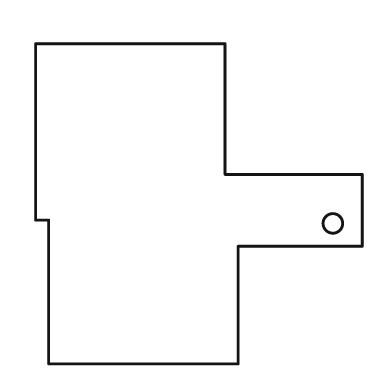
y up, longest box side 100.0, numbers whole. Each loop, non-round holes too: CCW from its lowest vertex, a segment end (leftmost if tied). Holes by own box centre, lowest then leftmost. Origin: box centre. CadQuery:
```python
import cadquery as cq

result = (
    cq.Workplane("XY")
    .moveTo(-46.0, -49.0)
    .lineTo(12.0, -49.0)
    .lineTo(12.0, -13.0)
    .lineTo(50.0, -13.0)
    .lineTo(50.0, 9.0)
    .lineTo(8.0, 9.0)
    .lineTo(8.0, 49.0)
    .lineTo(-50.0, 49.0)
    .lineTo(-50.0, -5.0)
    .lineTo(-46.0, -5.0)
    .close()
    .moveTo(41.0, -6.0)
    .circle(3.0)
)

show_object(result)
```